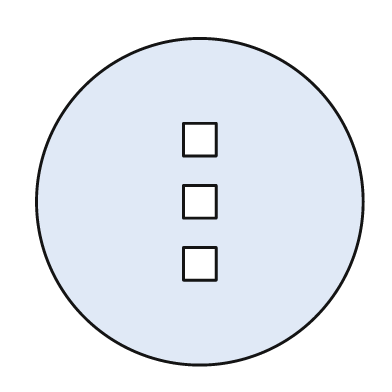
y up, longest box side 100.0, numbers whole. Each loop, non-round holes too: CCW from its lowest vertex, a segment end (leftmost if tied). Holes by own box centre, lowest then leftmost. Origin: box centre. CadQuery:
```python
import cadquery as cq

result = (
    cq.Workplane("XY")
    .moveTo(0.0, 0.0)
    .circle(50.0)
    .moveTo(-5.0, -24.0)
    .lineTo(5.0, -24.0)
    .lineTo(5.0, -14.0)
    .lineTo(-5.0, -14.0)
    .close()
    .moveTo(-5.0, -5.0)
    .lineTo(5.0, -5.0)
    .lineTo(5.0, 5.0)
    .lineTo(-5.0, 5.0)
    .close()
    .moveTo(-5.0, 14.0)
    .lineTo(5.0, 14.0)
    .lineTo(5.0, 24.0)
    .lineTo(-5.0, 24.0)
    .close()
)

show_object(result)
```